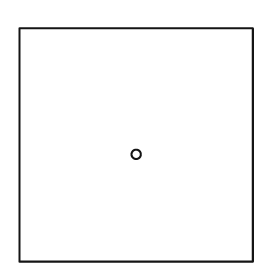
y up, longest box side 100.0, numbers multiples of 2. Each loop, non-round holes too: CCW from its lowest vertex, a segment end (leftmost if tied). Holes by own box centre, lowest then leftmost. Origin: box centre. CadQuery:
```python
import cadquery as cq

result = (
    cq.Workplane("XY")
    .moveTo(-50.0, -50.0)
    .lineTo(50.0, -50.0)
    .lineTo(50.0, 50.0)
    .lineTo(-50.0, 50.0)
    .close()
    .moveTo(0.0, -4.0)
    .circle(2.0)
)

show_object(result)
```